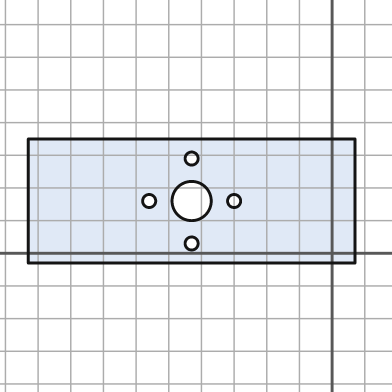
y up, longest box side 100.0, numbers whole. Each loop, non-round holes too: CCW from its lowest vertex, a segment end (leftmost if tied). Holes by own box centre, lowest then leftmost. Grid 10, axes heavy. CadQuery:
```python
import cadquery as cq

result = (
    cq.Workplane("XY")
    .moveTo(-93.0, -3.0)
    .lineTo(7.0, -3.0)
    .lineTo(7.0, 35.0)
    .lineTo(-93.0, 35.0)
    .close()
    .moveTo(-43.0, 3.0)
    .circle(2.0)
    .moveTo(-56.0, 16.0)
    .circle(2.0)
    .moveTo(-43.0, 16.0)
    .circle(6.0)
    .moveTo(-30.0, 16.0)
    .circle(2.0)
    .moveTo(-43.0, 29.0)
    .circle(2.0)
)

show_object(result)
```